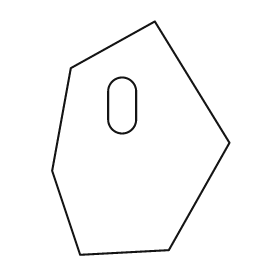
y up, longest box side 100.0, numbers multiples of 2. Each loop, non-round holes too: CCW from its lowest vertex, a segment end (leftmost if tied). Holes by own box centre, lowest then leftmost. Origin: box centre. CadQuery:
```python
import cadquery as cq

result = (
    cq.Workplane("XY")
    .moveTo(-26.0, -50.0)
    .lineTo(12.0, -48.0)
    .lineTo(38.0, -2.0)
    .lineTo(6.0, 50.0)
    .lineTo(-30.0, 30.0)
    .lineTo(-38.0, -14.0)
    .close()
    .moveTo(-14.0, 8.0)
    .threePointArc((-8.0, 2.0), (-2.0, 8.0))
    .lineTo(-2.0, 20.0)
    .threePointArc((-8.0, 26.0), (-14.0, 20.0))
    .close()
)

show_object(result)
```